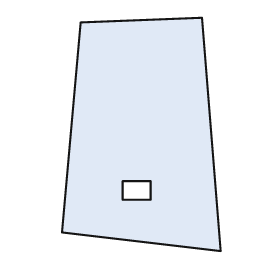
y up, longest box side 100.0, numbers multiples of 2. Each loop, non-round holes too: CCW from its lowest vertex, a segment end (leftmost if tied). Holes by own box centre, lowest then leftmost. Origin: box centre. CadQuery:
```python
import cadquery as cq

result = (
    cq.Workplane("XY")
    .moveTo(34.0, -50.0)
    .lineTo(26.0, 50.0)
    .lineTo(-26.0, 48.0)
    .lineTo(-34.0, -42.0)
    .close()
    .moveTo(-8.0, -28.0)
    .lineTo(4.0, -28.0)
    .lineTo(4.0, -20.0)
    .lineTo(-8.0, -20.0)
    .close()
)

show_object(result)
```